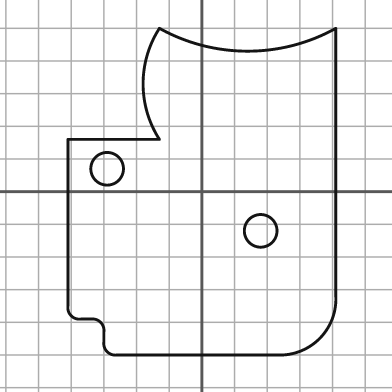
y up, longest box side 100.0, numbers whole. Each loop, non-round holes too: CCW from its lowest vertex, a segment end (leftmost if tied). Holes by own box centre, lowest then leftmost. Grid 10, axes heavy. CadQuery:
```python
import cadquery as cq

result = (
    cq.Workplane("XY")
    .moveTo(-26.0, -50.0)
    .lineTo(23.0, -50.0)
    .threePointArc((36.0, -45.0), (41.0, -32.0))
    .lineTo(41.0, 50.0)
    .threePointArc((14.0, 43.0), (-13.0, 50.0))
    .threePointArc((-18.0, 33.0), (-13.0, 16.0))
    .lineTo(-41.0, 16.0)
    .lineTo(-41.0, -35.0)
    .threePointArc((-40.0, -38.0), (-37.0, -39.0))
    .lineTo(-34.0, -39.0)
    .threePointArc((-31.0, -40.0), (-30.0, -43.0))
    .lineTo(-30.0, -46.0)
    .threePointArc((-29.0, -49.0), (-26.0, -50.0))
    .close()
    .moveTo(18.0, -12.0)
    .circle(5.0)
    .moveTo(-29.0, 7.0)
    .circle(5.0)
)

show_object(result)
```